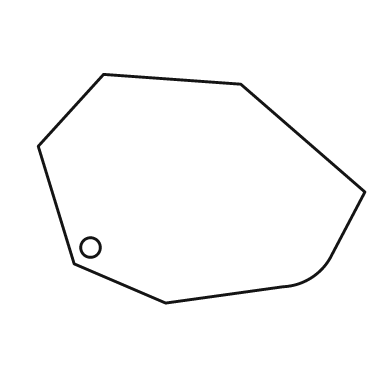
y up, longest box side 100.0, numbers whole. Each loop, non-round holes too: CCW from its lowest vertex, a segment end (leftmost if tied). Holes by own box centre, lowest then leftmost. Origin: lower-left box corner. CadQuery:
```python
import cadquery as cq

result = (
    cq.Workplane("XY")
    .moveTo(39.0, 0.0)
    .lineTo(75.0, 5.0)
    .threePointArc((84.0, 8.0), (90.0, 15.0))
    .lineTo(100.0, 34.0)
    .lineTo(62.0, 67.0)
    .lineTo(20.0, 70.0)
    .lineTo(0.0, 48.0)
    .lineTo(11.0, 12.0)
    .close()
    .moveTo(16.0, 17.0)
    .circle(3.0)
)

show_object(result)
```